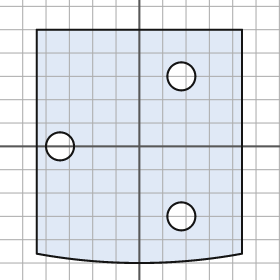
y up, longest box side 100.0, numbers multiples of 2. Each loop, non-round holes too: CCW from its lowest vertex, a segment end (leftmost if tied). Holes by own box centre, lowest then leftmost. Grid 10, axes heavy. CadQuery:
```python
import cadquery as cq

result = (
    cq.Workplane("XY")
    .moveTo(-44.0, -46.0)
    .threePointArc((0.0, -50.0), (44.0, -46.0))
    .lineTo(44.0, 50.0)
    .lineTo(-44.0, 50.0)
    .close()
    .moveTo(18.0, -30.0)
    .circle(6.0)
    .moveTo(-34.0, 0.0)
    .circle(6.0)
    .moveTo(18.0, 30.0)
    .circle(6.0)
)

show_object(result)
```